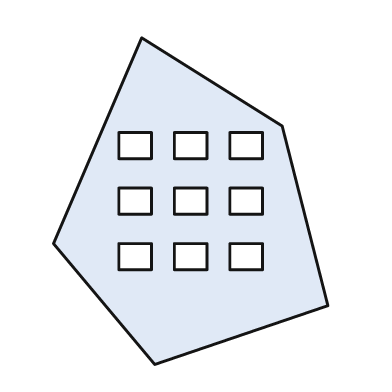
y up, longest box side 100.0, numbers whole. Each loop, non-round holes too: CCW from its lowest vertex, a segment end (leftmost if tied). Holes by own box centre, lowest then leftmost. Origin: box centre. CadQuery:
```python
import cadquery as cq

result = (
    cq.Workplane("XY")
    .moveTo(-11.0, -50.0)
    .lineTo(42.0, -32.0)
    .lineTo(28.0, 23.0)
    .lineTo(-15.0, 50.0)
    .lineTo(-42.0, -13.0)
    .close()
    .moveTo(-22.0, -21.0)
    .lineTo(-12.0, -21.0)
    .lineTo(-12.0, -13.0)
    .lineTo(-22.0, -13.0)
    .close()
    .moveTo(-5.0, -21.0)
    .lineTo(5.0, -21.0)
    .lineTo(5.0, -13.0)
    .lineTo(-5.0, -13.0)
    .close()
    .moveTo(12.0, -21.0)
    .lineTo(22.0, -21.0)
    .lineTo(22.0, -13.0)
    .lineTo(12.0, -13.0)
    .close()
    .moveTo(-22.0, -4.0)
    .lineTo(-12.0, -4.0)
    .lineTo(-12.0, 4.0)
    .lineTo(-22.0, 4.0)
    .close()
    .moveTo(-5.0, -4.0)
    .lineTo(5.0, -4.0)
    .lineTo(5.0, 4.0)
    .lineTo(-5.0, 4.0)
    .close()
    .moveTo(12.0, -4.0)
    .lineTo(22.0, -4.0)
    .lineTo(22.0, 4.0)
    .lineTo(12.0, 4.0)
    .close()
    .moveTo(-22.0, 13.0)
    .lineTo(-12.0, 13.0)
    .lineTo(-12.0, 21.0)
    .lineTo(-22.0, 21.0)
    .close()
    .moveTo(-5.0, 13.0)
    .lineTo(5.0, 13.0)
    .lineTo(5.0, 21.0)
    .lineTo(-5.0, 21.0)
    .close()
    .moveTo(12.0, 13.0)
    .lineTo(22.0, 13.0)
    .lineTo(22.0, 21.0)
    .lineTo(12.0, 21.0)
    .close()
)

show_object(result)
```